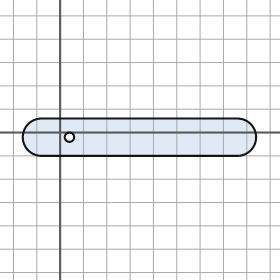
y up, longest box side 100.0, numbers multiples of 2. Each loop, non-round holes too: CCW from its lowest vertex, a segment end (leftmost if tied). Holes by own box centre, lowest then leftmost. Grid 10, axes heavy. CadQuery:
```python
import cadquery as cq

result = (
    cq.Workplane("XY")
    .moveTo(-8.0, -10.0)
    .lineTo(76.0, -10.0)
    .threePointArc((84.0, -2.0), (76.0, 6.0))
    .lineTo(-8.0, 6.0)
    .threePointArc((-16.0, -2.0), (-8.0, -10.0))
    .close()
    .moveTo(4.0, -2.0)
    .circle(2.0)
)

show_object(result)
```